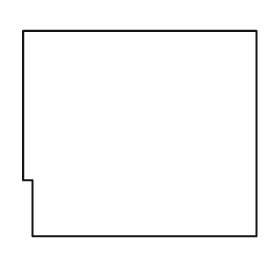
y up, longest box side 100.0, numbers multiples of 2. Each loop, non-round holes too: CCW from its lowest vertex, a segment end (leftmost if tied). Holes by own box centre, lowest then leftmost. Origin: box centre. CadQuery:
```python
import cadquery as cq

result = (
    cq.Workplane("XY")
    .moveTo(-46.0, -44.0)
    .lineTo(50.0, -44.0)
    .lineTo(50.0, 44.0)
    .lineTo(-50.0, 44.0)
    .lineTo(-50.0, -20.0)
    .lineTo(-46.0, -20.0)
    .close()
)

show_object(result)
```